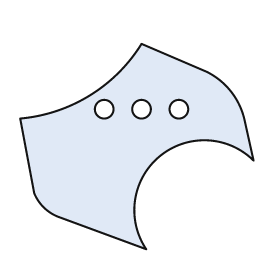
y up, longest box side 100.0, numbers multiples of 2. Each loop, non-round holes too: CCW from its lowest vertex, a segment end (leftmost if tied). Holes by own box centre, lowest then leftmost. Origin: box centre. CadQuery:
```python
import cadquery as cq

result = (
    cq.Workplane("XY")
    .moveTo(4.0, -44.0)
    .threePointArc((10.0, -4.0), (50.0, -6.0))
    .lineTo(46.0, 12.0)
    .threePointArc((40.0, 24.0), (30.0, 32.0))
    .lineTo(2.0, 44.0)
    .threePointArc((-20.0, 22.0), (-50.0, 12.0))
    .lineTo(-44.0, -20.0)
    .threePointArc((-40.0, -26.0), (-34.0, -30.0))
    .close()
    .moveTo(-14.0, 16.0)
    .circle(4.0)
    .moveTo(2.0, 16.0)
    .circle(4.0)
    .moveTo(18.0, 16.0)
    .circle(4.0)
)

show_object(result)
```